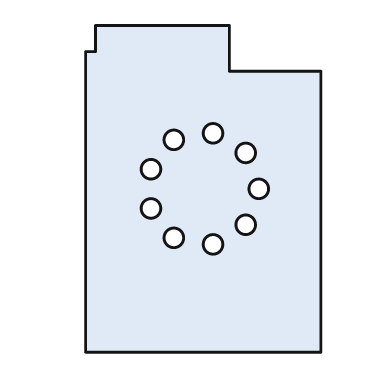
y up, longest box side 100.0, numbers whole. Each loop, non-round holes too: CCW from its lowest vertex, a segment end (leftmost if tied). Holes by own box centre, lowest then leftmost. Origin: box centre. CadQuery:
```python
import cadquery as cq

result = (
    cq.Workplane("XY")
    .moveTo(-36.0, -50.0)
    .lineTo(36.0, -50.0)
    .lineTo(36.0, 36.0)
    .lineTo(8.0, 36.0)
    .lineTo(8.0, 50.0)
    .lineTo(-33.0, 50.0)
    .lineTo(-33.0, 42.0)
    .lineTo(-36.0, 42.0)
    .close()
    .moveTo(3.0, -17.0)
    .circle(3.0)
    .moveTo(-9.0, -15.0)
    .circle(3.0)
    .moveTo(13.0, -11.0)
    .circle(3.0)
    .moveTo(-16.0, -6.0)
    .circle(3.0)
    .moveTo(17.0, 0.0)
    .circle(3.0)
    .moveTo(-16.0, 6.0)
    .circle(3.0)
    .moveTo(13.0, 11.0)
    .circle(3.0)
    .moveTo(-9.0, 15.0)
    .circle(3.0)
    .moveTo(3.0, 17.0)
    .circle(3.0)
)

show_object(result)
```